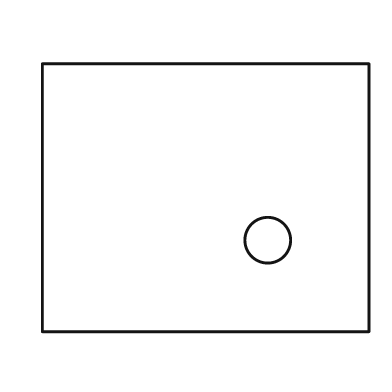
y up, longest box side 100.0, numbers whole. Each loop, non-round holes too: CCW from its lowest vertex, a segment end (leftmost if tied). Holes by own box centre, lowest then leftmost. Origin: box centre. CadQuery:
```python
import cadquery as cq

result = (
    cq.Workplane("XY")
    .moveTo(-50.0, -41.0)
    .lineTo(50.0, -41.0)
    .lineTo(50.0, 41.0)
    .lineTo(-50.0, 41.0)
    .close()
    .moveTo(19.0, -13.0)
    .circle(7.0)
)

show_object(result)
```